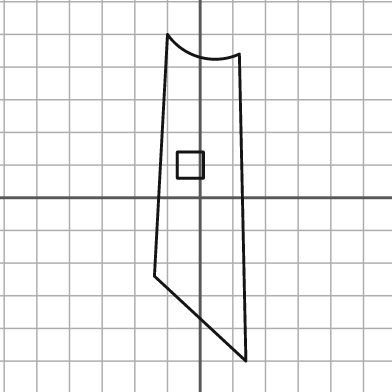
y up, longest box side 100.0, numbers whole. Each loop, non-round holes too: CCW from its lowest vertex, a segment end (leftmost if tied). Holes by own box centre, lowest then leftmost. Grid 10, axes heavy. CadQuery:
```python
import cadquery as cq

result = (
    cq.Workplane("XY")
    .moveTo(14.0, -50.0)
    .lineTo(12.0, 44.0)
    .threePointArc((0.0, 43.0), (-10.0, 50.0))
    .lineTo(-14.0, -24.0)
    .close()
    .moveTo(-7.0, 6.0)
    .lineTo(1.0, 6.0)
    .lineTo(1.0, 14.0)
    .lineTo(-7.0, 14.0)
    .close()
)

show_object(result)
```